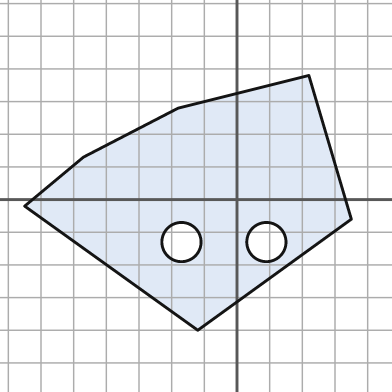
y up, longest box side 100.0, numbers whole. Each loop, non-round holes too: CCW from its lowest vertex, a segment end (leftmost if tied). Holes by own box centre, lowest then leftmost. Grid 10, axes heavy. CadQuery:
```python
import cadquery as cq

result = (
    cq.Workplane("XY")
    .moveTo(-12.0, -40.0)
    .lineTo(35.0, -6.0)
    .lineTo(22.0, 38.0)
    .lineTo(-18.0, 28.0)
    .lineTo(-47.0, 13.0)
    .lineTo(-65.0, -2.0)
    .close()
    .moveTo(-17.0, -13.0)
    .circle(6.0)
    .moveTo(9.0, -13.0)
    .circle(6.0)
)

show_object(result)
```